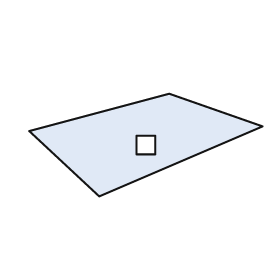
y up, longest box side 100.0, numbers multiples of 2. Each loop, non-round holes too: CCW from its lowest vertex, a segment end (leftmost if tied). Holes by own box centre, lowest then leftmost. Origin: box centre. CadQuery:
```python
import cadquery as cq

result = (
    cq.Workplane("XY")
    .moveTo(-20.0, -22.0)
    .lineTo(50.0, 8.0)
    .lineTo(10.0, 22.0)
    .lineTo(-50.0, 6.0)
    .close()
    .moveTo(-4.0, -4.0)
    .lineTo(4.0, -4.0)
    .lineTo(4.0, 4.0)
    .lineTo(-4.0, 4.0)
    .close()
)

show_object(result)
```